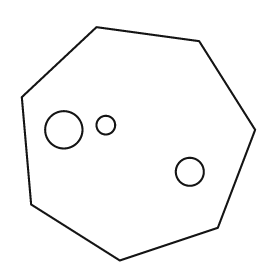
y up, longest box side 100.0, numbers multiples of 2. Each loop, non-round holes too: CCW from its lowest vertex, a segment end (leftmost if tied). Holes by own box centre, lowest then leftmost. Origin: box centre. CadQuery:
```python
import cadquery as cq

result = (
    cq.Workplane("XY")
    .moveTo(-8.0, -50.0)
    .lineTo(34.0, -36.0)
    .lineTo(50.0, 6.0)
    .lineTo(26.0, 44.0)
    .lineTo(-18.0, 50.0)
    .lineTo(-50.0, 20.0)
    .lineTo(-46.0, -26.0)
    .close()
    .moveTo(22.0, -12.0)
    .circle(6.0)
    .moveTo(-32.0, 6.0)
    .circle(8.0)
    .moveTo(-14.0, 8.0)
    .circle(4.0)
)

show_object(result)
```